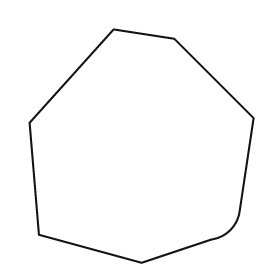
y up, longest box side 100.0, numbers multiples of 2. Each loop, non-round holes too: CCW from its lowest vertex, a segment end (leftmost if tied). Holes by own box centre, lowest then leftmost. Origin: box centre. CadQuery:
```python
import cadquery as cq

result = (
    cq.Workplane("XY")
    .moveTo(0.0, -50.0)
    .lineTo(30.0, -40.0)
    .threePointArc((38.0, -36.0), (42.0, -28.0))
    .lineTo(48.0, 12.0)
    .lineTo(14.0, 46.0)
    .lineTo(-12.0, 50.0)
    .lineTo(-48.0, 10.0)
    .lineTo(-44.0, -38.0)
    .close()
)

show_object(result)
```